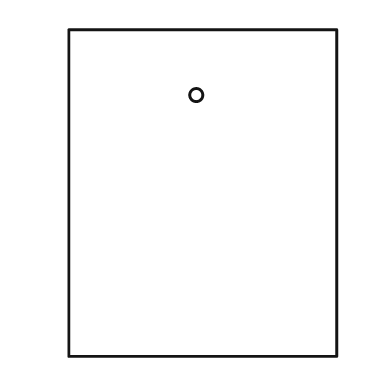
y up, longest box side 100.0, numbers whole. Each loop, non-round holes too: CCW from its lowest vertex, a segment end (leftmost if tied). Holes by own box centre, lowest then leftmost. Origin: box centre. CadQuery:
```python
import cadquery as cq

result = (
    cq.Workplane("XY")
    .moveTo(-41.0, -50.0)
    .lineTo(41.0, -50.0)
    .lineTo(41.0, 50.0)
    .lineTo(-41.0, 50.0)
    .close()
    .moveTo(-2.0, 30.0)
    .circle(2.0)
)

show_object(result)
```